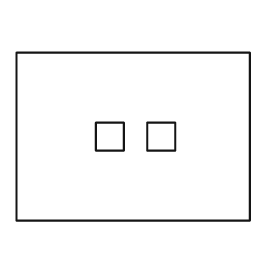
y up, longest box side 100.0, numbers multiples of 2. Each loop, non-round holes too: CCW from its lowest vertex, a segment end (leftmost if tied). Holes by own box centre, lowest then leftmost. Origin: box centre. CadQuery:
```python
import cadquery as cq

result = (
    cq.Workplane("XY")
    .moveTo(-50.0, -36.0)
    .lineTo(50.0, -36.0)
    .lineTo(50.0, 36.0)
    .lineTo(-50.0, 36.0)
    .close()
    .moveTo(-16.0, -6.0)
    .lineTo(-4.0, -6.0)
    .lineTo(-4.0, 6.0)
    .lineTo(-16.0, 6.0)
    .close()
    .moveTo(6.0, -6.0)
    .lineTo(18.0, -6.0)
    .lineTo(18.0, 6.0)
    .lineTo(6.0, 6.0)
    .close()
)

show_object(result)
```